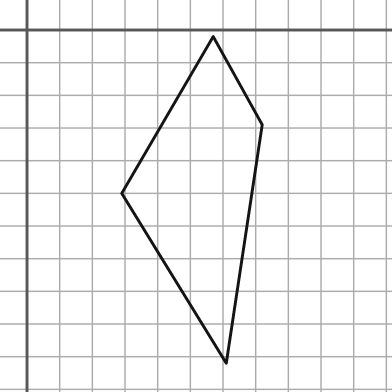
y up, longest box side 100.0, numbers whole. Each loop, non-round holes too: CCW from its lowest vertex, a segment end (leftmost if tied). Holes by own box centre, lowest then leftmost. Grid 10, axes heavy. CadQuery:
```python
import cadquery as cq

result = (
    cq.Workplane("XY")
    .moveTo(61.0, -102.0)
    .lineTo(72.0, -29.0)
    .lineTo(57.0, -2.0)
    .lineTo(29.0, -50.0)
    .close()
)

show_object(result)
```